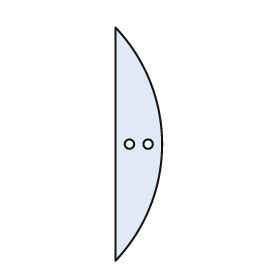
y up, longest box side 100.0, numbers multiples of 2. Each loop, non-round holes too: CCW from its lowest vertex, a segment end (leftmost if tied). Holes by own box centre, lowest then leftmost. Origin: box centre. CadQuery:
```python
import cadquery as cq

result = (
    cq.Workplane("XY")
    .moveTo(-10.0, -50.0)
    .threePointArc((10.0, 0.0), (-10.0, 50.0))
    .close()
    .moveTo(-4.0, 0.0)
    .circle(2.0)
    .moveTo(4.0, 0.0)
    .circle(2.0)
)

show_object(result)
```